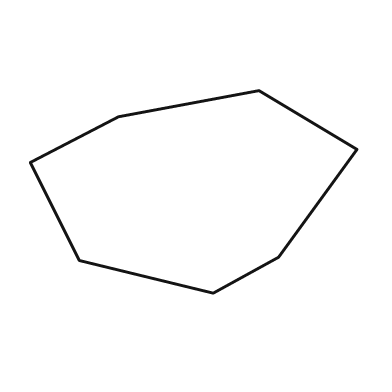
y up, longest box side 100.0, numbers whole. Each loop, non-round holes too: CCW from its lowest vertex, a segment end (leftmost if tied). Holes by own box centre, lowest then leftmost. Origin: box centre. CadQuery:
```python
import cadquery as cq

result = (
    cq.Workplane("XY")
    .moveTo(6.0, -31.0)
    .lineTo(26.0, -20.0)
    .lineTo(50.0, 13.0)
    .lineTo(20.0, 31.0)
    .lineTo(-23.0, 23.0)
    .lineTo(-50.0, 9.0)
    .lineTo(-35.0, -21.0)
    .close()
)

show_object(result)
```